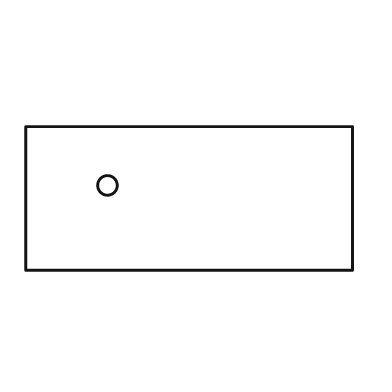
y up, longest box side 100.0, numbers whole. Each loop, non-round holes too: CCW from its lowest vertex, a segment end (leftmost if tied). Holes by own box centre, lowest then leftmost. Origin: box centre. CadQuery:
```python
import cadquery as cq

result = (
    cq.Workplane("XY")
    .moveTo(-50.0, -22.0)
    .lineTo(50.0, -22.0)
    .lineTo(50.0, 22.0)
    .lineTo(-50.0, 22.0)
    .close()
    .moveTo(-25.0, 4.0)
    .circle(3.0)
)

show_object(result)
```